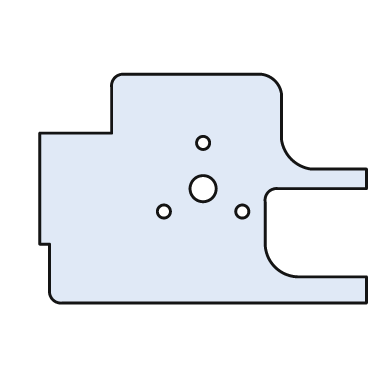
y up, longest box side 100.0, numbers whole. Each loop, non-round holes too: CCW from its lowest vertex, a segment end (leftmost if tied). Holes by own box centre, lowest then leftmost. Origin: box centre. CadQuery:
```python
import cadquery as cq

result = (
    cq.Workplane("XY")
    .moveTo(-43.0, -35.0)
    .lineTo(50.0, -35.0)
    .lineTo(50.0, -27.0)
    .lineTo(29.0, -27.0)
    .threePointArc((22.0, -24.0), (19.0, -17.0))
    .lineTo(19.0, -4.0)
    .threePointArc((20.0, -1.0), (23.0, 0.0))
    .lineTo(50.0, 0.0)
    .lineTo(50.0, 6.0)
    .lineTo(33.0, 6.0)
    .threePointArc((27.0, 9.0), (24.0, 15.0))
    .lineTo(24.0, 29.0)
    .threePointArc((22.0, 33.0), (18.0, 35.0))
    .lineTo(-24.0, 35.0)
    .threePointArc((-27.0, 34.0), (-28.0, 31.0))
    .lineTo(-28.0, 17.0)
    .lineTo(-50.0, 17.0)
    .lineTo(-50.0, -17.0)
    .lineTo(-47.0, -17.0)
    .lineTo(-47.0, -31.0)
    .threePointArc((-46.0, -34.0), (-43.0, -35.0))
    .close()
    .moveTo(-12.0, -7.0)
    .circle(2.0)
    .moveTo(12.0, -7.0)
    .circle(2.0)
    .moveTo(0.0, 0.0)
    .circle(4.0)
    .moveTo(0.0, 14.0)
    .circle(2.0)
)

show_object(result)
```